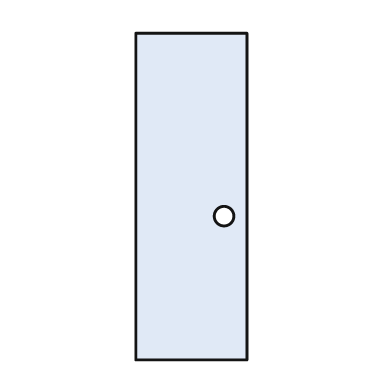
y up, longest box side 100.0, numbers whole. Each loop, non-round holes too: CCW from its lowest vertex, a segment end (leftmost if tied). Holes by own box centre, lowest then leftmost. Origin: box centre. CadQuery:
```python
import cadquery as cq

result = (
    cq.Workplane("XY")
    .moveTo(-17.0, -50.0)
    .lineTo(17.0, -50.0)
    .lineTo(17.0, 50.0)
    .lineTo(-17.0, 50.0)
    .close()
    .moveTo(10.0, -6.0)
    .circle(3.0)
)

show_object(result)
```